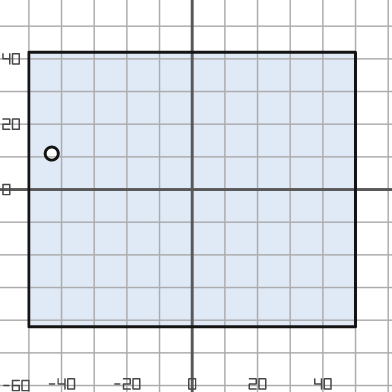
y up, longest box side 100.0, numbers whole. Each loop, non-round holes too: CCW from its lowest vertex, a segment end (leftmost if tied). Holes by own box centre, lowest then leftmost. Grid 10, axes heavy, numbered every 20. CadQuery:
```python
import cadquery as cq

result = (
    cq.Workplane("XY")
    .moveTo(-50.0, -42.0)
    .lineTo(50.0, -42.0)
    .lineTo(50.0, 42.0)
    .lineTo(-50.0, 42.0)
    .close()
    .moveTo(-43.0, 11.0)
    .circle(2.0)
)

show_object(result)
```